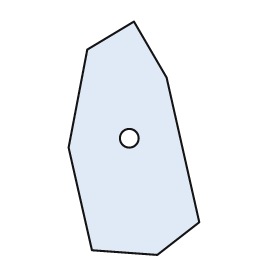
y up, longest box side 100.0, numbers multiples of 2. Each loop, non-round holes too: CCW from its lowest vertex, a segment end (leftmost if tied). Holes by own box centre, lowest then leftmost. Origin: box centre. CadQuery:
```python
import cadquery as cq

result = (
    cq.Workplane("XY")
    .moveTo(10.0, -50.0)
    .lineTo(28.0, -36.0)
    .lineTo(14.0, 26.0)
    .lineTo(0.0, 50.0)
    .lineTo(-20.0, 38.0)
    .lineTo(-28.0, -4.0)
    .lineTo(-18.0, -48.0)
    .close()
    .moveTo(-2.0, 0.0)
    .circle(4.0)
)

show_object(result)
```